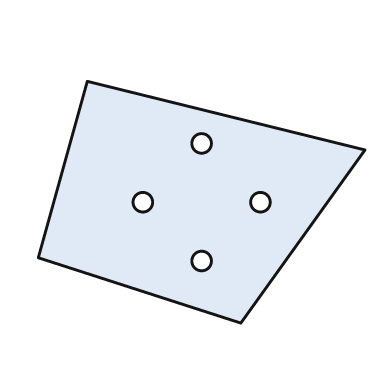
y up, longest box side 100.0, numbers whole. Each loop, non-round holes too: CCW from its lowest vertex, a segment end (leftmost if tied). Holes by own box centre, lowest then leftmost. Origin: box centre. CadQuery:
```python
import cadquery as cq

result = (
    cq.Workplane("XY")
    .moveTo(12.0, -37.0)
    .lineTo(50.0, 16.0)
    .lineTo(-35.0, 37.0)
    .lineTo(-50.0, -17.0)
    .close()
    .moveTo(0.0, -18.0)
    .circle(3.0)
    .moveTo(-18.0, 0.0)
    .circle(3.0)
    .moveTo(18.0, 0.0)
    .circle(3.0)
    .moveTo(0.0, 18.0)
    .circle(3.0)
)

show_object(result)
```